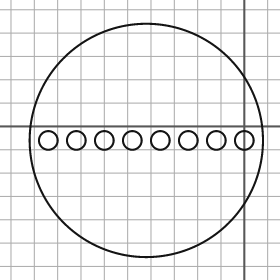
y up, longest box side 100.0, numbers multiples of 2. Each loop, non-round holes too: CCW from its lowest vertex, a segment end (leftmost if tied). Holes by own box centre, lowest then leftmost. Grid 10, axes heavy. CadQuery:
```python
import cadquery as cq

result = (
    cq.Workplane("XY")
    .moveTo(-42.0, -6.0)
    .circle(50.0)
    .moveTo(-84.0, -6.0)
    .circle(4.0)
    .moveTo(-72.0, -6.0)
    .circle(4.0)
    .moveTo(-60.0, -6.0)
    .circle(4.0)
    .moveTo(-48.0, -6.0)
    .circle(4.0)
    .moveTo(-36.0, -6.0)
    .circle(4.0)
    .moveTo(-24.0, -6.0)
    .circle(4.0)
    .moveTo(-12.0, -6.0)
    .circle(4.0)
    .moveTo(0.0, -6.0)
    .circle(4.0)
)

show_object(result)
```